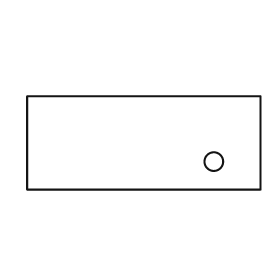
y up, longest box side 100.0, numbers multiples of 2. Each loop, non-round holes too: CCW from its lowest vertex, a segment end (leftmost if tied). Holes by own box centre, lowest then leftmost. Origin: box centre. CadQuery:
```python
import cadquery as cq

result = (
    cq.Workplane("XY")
    .moveTo(-50.0, -20.0)
    .lineTo(50.0, -20.0)
    .lineTo(50.0, 20.0)
    .lineTo(-50.0, 20.0)
    .close()
    .moveTo(30.0, -8.0)
    .circle(4.0)
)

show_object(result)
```